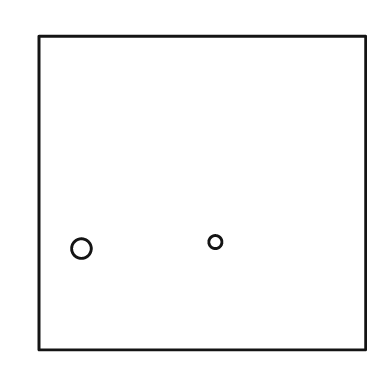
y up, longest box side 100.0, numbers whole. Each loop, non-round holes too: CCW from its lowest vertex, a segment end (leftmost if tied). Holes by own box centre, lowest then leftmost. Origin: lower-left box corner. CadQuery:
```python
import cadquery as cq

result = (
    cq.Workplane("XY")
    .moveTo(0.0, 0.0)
    .lineTo(100.0, 0.0)
    .lineTo(100.0, 96.0)
    .lineTo(0.0, 96.0)
    .close()
    .moveTo(13.0, 31.0)
    .circle(3.0)
    .moveTo(54.0, 33.0)
    .circle(2.0)
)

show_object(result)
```